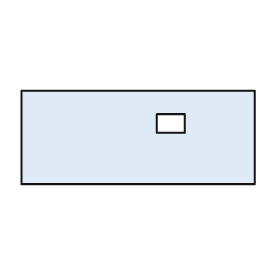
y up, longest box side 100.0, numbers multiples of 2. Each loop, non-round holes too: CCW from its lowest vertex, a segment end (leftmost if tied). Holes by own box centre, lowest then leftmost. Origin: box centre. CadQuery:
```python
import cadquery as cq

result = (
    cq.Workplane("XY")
    .moveTo(-50.0, -20.0)
    .lineTo(50.0, -20.0)
    .lineTo(50.0, 20.0)
    .lineTo(-50.0, 20.0)
    .close()
    .moveTo(8.0, 2.0)
    .lineTo(20.0, 2.0)
    .lineTo(20.0, 10.0)
    .lineTo(8.0, 10.0)
    .close()
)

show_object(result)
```